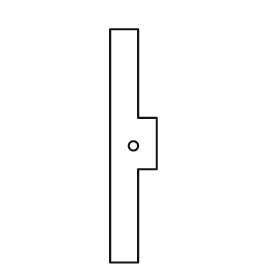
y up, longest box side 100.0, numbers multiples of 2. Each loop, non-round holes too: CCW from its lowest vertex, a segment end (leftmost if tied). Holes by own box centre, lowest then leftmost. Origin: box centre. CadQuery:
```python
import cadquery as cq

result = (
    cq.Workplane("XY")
    .moveTo(-10.0, -50.0)
    .lineTo(2.0, -50.0)
    .lineTo(2.0, -10.0)
    .lineTo(10.0, -10.0)
    .lineTo(10.0, 12.0)
    .lineTo(2.0, 12.0)
    .lineTo(2.0, 50.0)
    .lineTo(-10.0, 50.0)
    .close()
    .moveTo(0.0, 0.0)
    .circle(2.0)
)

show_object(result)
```